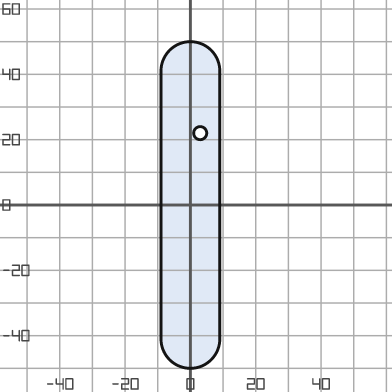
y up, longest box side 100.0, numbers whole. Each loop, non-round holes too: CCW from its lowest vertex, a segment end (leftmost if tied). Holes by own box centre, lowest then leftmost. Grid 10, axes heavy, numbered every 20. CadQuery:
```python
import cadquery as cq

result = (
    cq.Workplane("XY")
    .moveTo(-9.0, -41.0)
    .threePointArc((0.0, -50.0), (9.0, -41.0))
    .lineTo(9.0, 41.0)
    .threePointArc((0.0, 50.0), (-9.0, 41.0))
    .close()
    .moveTo(3.0, 22.0)
    .circle(2.0)
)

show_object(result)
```